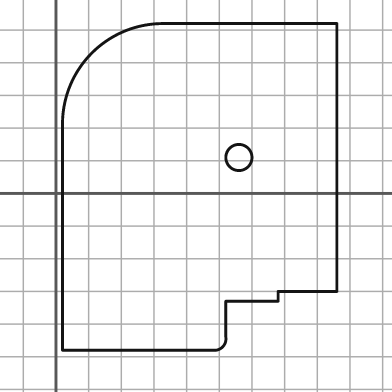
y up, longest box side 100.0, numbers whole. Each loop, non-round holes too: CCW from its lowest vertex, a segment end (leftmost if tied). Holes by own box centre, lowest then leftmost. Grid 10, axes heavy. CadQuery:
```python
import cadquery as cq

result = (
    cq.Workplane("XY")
    .moveTo(2.0, -48.0)
    .lineTo(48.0, -48.0)
    .threePointArc((51.0, -47.0), (52.0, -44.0))
    .lineTo(52.0, -33.0)
    .lineTo(68.0, -33.0)
    .lineTo(68.0, -30.0)
    .lineTo(86.0, -30.0)
    .lineTo(86.0, 52.0)
    .lineTo(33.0, 52.0)
    .threePointArc((11.0, 43.0), (2.0, 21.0))
    .close()
    .moveTo(56.0, 11.0)
    .circle(4.0)
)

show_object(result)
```